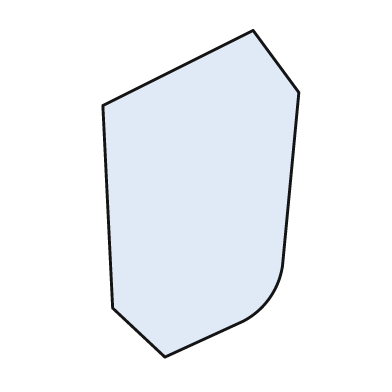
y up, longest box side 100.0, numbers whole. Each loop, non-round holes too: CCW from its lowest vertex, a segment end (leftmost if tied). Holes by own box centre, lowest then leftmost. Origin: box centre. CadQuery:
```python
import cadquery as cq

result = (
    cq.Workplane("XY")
    .moveTo(-11.0, -50.0)
    .lineTo(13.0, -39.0)
    .threePointArc((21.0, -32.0), (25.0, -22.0))
    .lineTo(30.0, 31.0)
    .lineTo(16.0, 50.0)
    .lineTo(-30.0, 27.0)
    .lineTo(-27.0, -35.0)
    .close()
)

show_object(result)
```